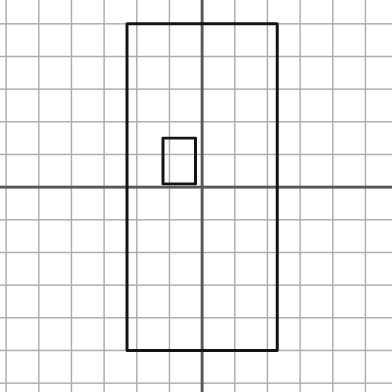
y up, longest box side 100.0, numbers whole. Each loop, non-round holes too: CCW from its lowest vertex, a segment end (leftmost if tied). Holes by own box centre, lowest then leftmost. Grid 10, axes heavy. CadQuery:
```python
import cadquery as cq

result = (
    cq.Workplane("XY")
    .moveTo(-23.0, -50.0)
    .lineTo(23.0, -50.0)
    .lineTo(23.0, 50.0)
    .lineTo(-23.0, 50.0)
    .close()
    .moveTo(-12.0, 1.0)
    .lineTo(-2.0, 1.0)
    .lineTo(-2.0, 15.0)
    .lineTo(-12.0, 15.0)
    .close()
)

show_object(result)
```